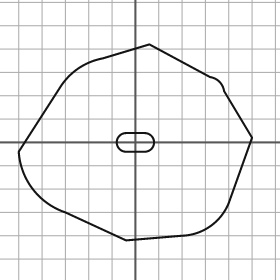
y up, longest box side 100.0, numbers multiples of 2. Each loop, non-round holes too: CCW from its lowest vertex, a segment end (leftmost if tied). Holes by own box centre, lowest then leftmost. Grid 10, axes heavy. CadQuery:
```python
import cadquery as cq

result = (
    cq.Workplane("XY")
    .moveTo(-4.0, -42.0)
    .lineTo(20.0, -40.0)
    .threePointArc((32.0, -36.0), (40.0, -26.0))
    .lineTo(50.0, 2.0)
    .lineTo(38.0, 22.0)
    .threePointArc((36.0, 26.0), (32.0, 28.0))
    .lineTo(6.0, 42.0)
    .lineTo(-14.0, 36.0)
    .threePointArc((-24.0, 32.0), (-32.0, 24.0))
    .lineTo(-50.0, -4.0)
    .threePointArc((-44.0, -20.0), (-30.0, -30.0))
    .close()
    .moveTo(-4.0, -4.0)
    .lineTo(4.0, -4.0)
    .threePointArc((8.0, 0.0), (4.0, 4.0))
    .lineTo(-4.0, 4.0)
    .threePointArc((-8.0, 0.0), (-4.0, -4.0))
    .close()
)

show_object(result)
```